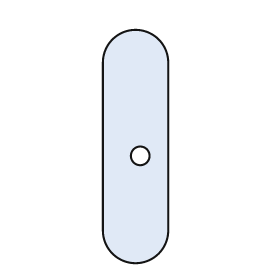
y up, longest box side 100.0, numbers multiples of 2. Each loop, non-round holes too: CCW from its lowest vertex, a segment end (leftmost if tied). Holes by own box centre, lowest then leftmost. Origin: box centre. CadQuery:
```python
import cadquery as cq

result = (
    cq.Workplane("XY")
    .moveTo(-14.0, -36.0)
    .threePointArc((0.0, -50.0), (14.0, -36.0))
    .lineTo(14.0, 36.0)
    .threePointArc((0.0, 50.0), (-14.0, 36.0))
    .close()
    .moveTo(2.0, -4.0)
    .circle(4.0)
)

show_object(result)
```